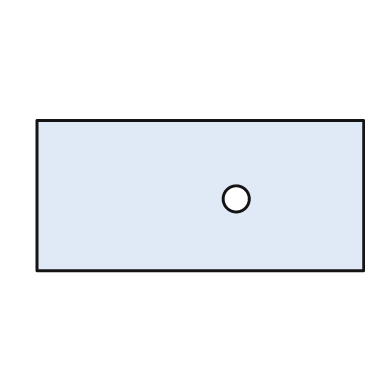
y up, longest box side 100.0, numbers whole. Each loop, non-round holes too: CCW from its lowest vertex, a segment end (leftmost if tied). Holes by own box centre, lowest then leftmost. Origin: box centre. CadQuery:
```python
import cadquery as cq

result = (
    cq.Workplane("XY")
    .moveTo(-50.0, -23.0)
    .lineTo(50.0, -23.0)
    .lineTo(50.0, 23.0)
    .lineTo(-50.0, 23.0)
    .close()
    .moveTo(11.0, -1.0)
    .circle(4.0)
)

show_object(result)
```